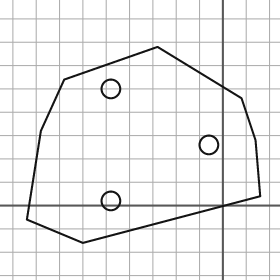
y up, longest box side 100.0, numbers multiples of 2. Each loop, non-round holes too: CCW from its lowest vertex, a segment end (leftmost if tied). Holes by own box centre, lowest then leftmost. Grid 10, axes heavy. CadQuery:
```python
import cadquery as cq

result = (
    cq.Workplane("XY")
    .moveTo(-60.0, -16.0)
    .lineTo(16.0, 4.0)
    .lineTo(14.0, 28.0)
    .lineTo(8.0, 46.0)
    .lineTo(-28.0, 68.0)
    .lineTo(-68.0, 54.0)
    .lineTo(-78.0, 32.0)
    .lineTo(-84.0, -6.0)
    .close()
    .moveTo(-48.0, 2.0)
    .circle(4.0)
    .moveTo(-6.0, 26.0)
    .circle(4.0)
    .moveTo(-48.0, 50.0)
    .circle(4.0)
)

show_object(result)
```